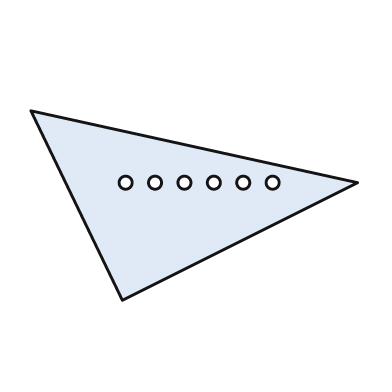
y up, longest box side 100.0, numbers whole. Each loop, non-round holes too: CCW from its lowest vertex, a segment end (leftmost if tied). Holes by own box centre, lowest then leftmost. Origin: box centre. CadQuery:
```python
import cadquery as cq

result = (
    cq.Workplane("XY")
    .moveTo(-22.0, -29.0)
    .lineTo(50.0, 7.0)
    .lineTo(-50.0, 29.0)
    .close()
    .moveTo(-21.0, 7.0)
    .circle(2.0)
    .moveTo(-12.0, 7.0)
    .circle(2.0)
    .moveTo(-3.0, 7.0)
    .circle(2.0)
    .moveTo(6.0, 7.0)
    .circle(2.0)
    .moveTo(15.0, 7.0)
    .circle(2.0)
    .moveTo(24.0, 7.0)
    .circle(2.0)
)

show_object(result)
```